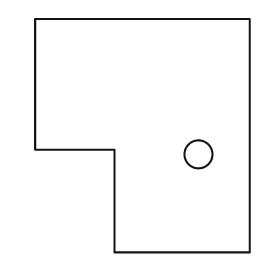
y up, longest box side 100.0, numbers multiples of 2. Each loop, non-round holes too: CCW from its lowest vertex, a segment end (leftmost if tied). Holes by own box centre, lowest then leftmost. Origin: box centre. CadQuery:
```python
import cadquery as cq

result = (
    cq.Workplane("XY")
    .moveTo(-12.0, -50.0)
    .lineTo(46.0, -50.0)
    .lineTo(46.0, 50.0)
    .lineTo(-46.0, 50.0)
    .lineTo(-46.0, -6.0)
    .lineTo(-12.0, -6.0)
    .close()
    .moveTo(24.0, -8.0)
    .circle(6.0)
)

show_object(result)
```